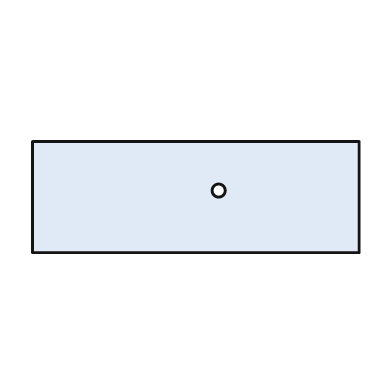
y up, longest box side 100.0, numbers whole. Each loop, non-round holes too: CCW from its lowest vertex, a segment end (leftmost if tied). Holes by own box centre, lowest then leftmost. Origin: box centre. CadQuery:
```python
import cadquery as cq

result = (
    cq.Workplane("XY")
    .moveTo(-50.0, -17.0)
    .lineTo(50.0, -17.0)
    .lineTo(50.0, 17.0)
    .lineTo(-50.0, 17.0)
    .close()
    .moveTo(7.0, 2.0)
    .circle(2.0)
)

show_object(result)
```